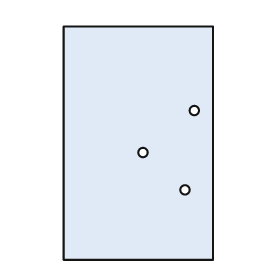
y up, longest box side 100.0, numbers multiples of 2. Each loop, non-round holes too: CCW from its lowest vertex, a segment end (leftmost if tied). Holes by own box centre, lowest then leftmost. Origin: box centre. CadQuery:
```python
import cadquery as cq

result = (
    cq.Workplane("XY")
    .moveTo(-32.0, -50.0)
    .lineTo(32.0, -50.0)
    .lineTo(32.0, 50.0)
    .lineTo(-32.0, 50.0)
    .close()
    .moveTo(20.0, -20.0)
    .circle(2.0)
    .moveTo(2.0, -4.0)
    .circle(2.0)
    .moveTo(24.0, 14.0)
    .circle(2.0)
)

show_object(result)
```